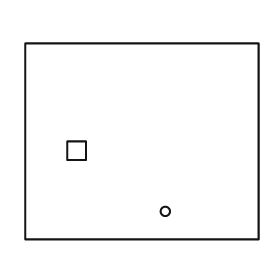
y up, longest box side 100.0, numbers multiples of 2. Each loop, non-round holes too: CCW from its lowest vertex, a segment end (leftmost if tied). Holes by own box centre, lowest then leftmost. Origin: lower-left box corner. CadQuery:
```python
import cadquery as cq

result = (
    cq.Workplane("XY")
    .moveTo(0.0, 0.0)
    .lineTo(100.0, 0.0)
    .lineTo(100.0, 84.0)
    .lineTo(0.0, 84.0)
    .close()
    .moveTo(60.0, 12.0)
    .circle(2.0)
    .moveTo(18.0, 34.0)
    .lineTo(26.0, 34.0)
    .lineTo(26.0, 42.0)
    .lineTo(18.0, 42.0)
    .close()
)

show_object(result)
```